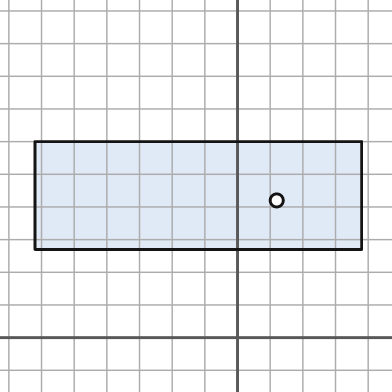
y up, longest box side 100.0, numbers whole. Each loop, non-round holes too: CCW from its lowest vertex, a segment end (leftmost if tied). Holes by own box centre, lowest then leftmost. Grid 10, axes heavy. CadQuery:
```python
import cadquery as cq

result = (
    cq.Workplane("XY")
    .moveTo(-62.0, 27.0)
    .lineTo(38.0, 27.0)
    .lineTo(38.0, 60.0)
    .lineTo(-62.0, 60.0)
    .close()
    .moveTo(12.0, 42.0)
    .circle(2.0)
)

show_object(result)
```